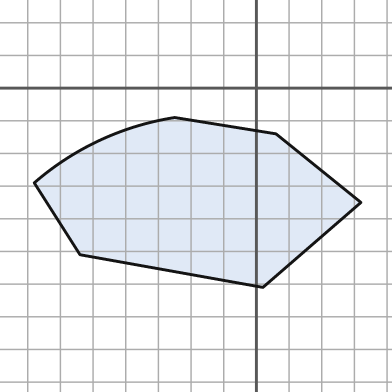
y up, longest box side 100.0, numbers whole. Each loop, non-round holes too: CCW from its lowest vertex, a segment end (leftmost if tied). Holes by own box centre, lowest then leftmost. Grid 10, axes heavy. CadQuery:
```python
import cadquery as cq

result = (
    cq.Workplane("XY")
    .moveTo(2.0, -61.0)
    .lineTo(32.0, -35.0)
    .lineTo(6.0, -14.0)
    .lineTo(-25.0, -9.0)
    .threePointArc((-48.0, -16.0), (-68.0, -29.0))
    .lineTo(-54.0, -51.0)
    .close()
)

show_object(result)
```